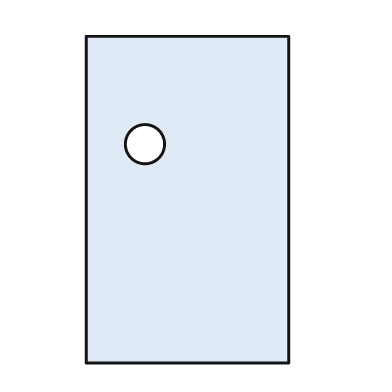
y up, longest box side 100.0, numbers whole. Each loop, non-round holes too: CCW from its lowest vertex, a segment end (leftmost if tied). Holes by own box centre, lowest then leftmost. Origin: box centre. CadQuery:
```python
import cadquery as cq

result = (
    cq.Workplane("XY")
    .moveTo(-31.0, -50.0)
    .lineTo(31.0, -50.0)
    .lineTo(31.0, 50.0)
    .lineTo(-31.0, 50.0)
    .close()
    .moveTo(-13.0, 17.0)
    .circle(6.0)
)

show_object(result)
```